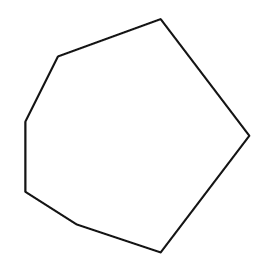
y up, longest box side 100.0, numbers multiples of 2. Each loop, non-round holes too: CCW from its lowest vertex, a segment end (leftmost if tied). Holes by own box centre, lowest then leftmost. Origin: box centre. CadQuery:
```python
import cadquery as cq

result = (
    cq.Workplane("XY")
    .moveTo(10.0, -50.0)
    .lineTo(48.0, 0.0)
    .lineTo(10.0, 50.0)
    .lineTo(-34.0, 34.0)
    .lineTo(-48.0, 6.0)
    .lineTo(-48.0, -24.0)
    .lineTo(-26.0, -38.0)
    .close()
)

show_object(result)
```